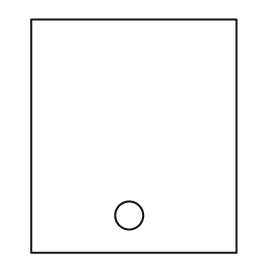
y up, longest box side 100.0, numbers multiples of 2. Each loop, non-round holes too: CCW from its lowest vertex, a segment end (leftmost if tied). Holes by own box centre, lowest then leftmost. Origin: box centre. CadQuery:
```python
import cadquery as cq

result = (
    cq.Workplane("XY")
    .moveTo(-44.0, -50.0)
    .lineTo(44.0, -50.0)
    .lineTo(44.0, 50.0)
    .lineTo(-44.0, 50.0)
    .close()
    .moveTo(-2.0, -34.0)
    .circle(6.0)
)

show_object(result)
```